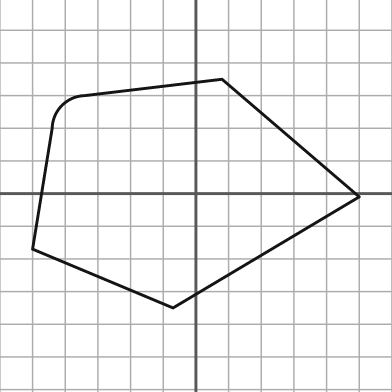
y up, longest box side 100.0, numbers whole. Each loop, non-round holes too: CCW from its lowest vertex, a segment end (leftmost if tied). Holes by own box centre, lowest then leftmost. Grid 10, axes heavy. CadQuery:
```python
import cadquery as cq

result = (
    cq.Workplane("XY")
    .moveTo(-7.0, -35.0)
    .lineTo(50.0, -1.0)
    .lineTo(8.0, 35.0)
    .lineTo(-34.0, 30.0)
    .threePointArc((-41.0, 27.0), (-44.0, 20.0))
    .lineTo(-50.0, -17.0)
    .close()
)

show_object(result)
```